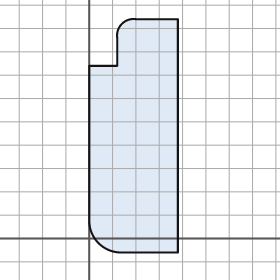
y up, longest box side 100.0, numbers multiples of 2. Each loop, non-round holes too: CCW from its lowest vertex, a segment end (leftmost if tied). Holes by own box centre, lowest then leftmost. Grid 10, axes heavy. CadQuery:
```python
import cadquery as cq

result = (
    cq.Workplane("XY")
    .moveTo(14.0, -6.0)
    .lineTo(38.0, -6.0)
    .lineTo(38.0, 94.0)
    .lineTo(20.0, 94.0)
    .threePointArc((14.0, 92.0), (12.0, 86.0))
    .lineTo(12.0, 74.0)
    .lineTo(0.0, 74.0)
    .lineTo(0.0, 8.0)
    .threePointArc((4.0, -2.0), (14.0, -6.0))
    .close()
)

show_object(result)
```